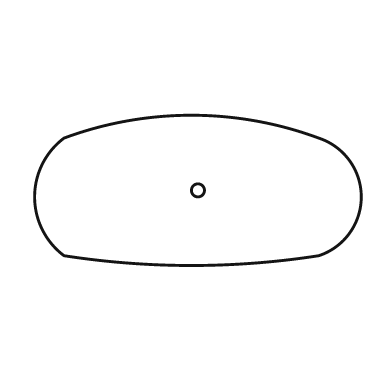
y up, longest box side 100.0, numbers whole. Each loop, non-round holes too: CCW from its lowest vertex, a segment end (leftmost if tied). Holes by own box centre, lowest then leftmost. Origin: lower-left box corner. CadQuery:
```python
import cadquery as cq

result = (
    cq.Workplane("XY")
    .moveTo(9.0, 3.0)
    .threePointArc((48.0, 0.0), (87.0, 3.0))
    .threePointArc((100.0, 21.0), (87.0, 39.0))
    .threePointArc((48.0, 46.0), (9.0, 39.0))
    .threePointArc((0.0, 21.0), (9.0, 3.0))
    .close()
    .moveTo(50.0, 23.0)
    .circle(2.0)
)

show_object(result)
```